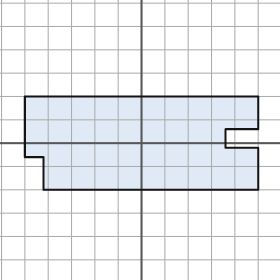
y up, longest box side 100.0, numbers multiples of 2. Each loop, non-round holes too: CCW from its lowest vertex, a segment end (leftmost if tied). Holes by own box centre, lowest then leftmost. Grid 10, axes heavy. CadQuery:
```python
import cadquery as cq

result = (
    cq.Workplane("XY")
    .moveTo(-42.0, -20.0)
    .lineTo(50.0, -20.0)
    .lineTo(50.0, -2.0)
    .lineTo(36.0, -2.0)
    .lineTo(36.0, 6.0)
    .lineTo(50.0, 6.0)
    .lineTo(50.0, 20.0)
    .lineTo(-50.0, 20.0)
    .lineTo(-50.0, -6.0)
    .lineTo(-42.0, -6.0)
    .close()
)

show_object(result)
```